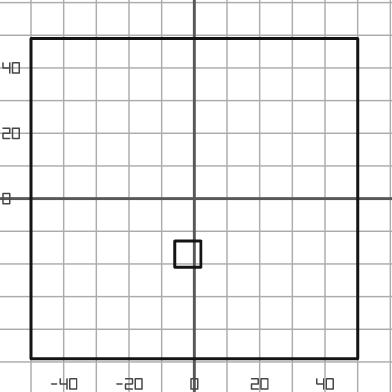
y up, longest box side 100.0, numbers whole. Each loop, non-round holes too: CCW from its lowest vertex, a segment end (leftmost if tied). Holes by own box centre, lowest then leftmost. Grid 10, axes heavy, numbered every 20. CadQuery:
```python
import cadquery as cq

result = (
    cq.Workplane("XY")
    .moveTo(-50.0, -49.0)
    .lineTo(50.0, -49.0)
    .lineTo(50.0, 49.0)
    .lineTo(-50.0, 49.0)
    .close()
    .moveTo(-6.0, -21.0)
    .lineTo(2.0, -21.0)
    .lineTo(2.0, -13.0)
    .lineTo(-6.0, -13.0)
    .close()
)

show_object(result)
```